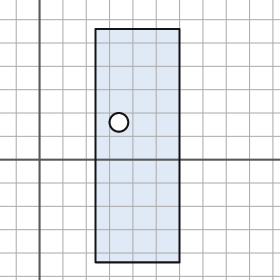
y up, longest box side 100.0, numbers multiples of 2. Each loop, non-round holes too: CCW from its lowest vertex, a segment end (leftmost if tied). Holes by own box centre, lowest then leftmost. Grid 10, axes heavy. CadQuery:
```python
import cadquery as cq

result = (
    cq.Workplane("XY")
    .moveTo(24.0, -44.0)
    .lineTo(60.0, -44.0)
    .lineTo(60.0, 56.0)
    .lineTo(24.0, 56.0)
    .close()
    .moveTo(34.0, 16.0)
    .circle(4.0)
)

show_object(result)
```